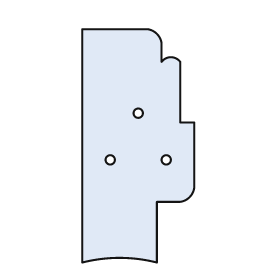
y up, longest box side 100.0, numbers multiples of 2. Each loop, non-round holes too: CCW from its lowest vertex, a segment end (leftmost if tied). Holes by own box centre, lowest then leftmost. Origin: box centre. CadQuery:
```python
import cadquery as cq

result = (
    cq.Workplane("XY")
    .moveTo(-24.0, -50.0)
    .threePointArc((-8.0, -48.0), (8.0, -50.0))
    .lineTo(8.0, -24.0)
    .lineTo(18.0, -24.0)
    .threePointArc((22.0, -22.0), (24.0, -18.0))
    .lineTo(24.0, 10.0)
    .lineTo(18.0, 10.0)
    .lineTo(18.0, 36.0)
    .threePointArc((14.0, 38.0), (10.0, 36.0))
    .lineTo(10.0, 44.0)
    .threePointArc((8.0, 48.0), (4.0, 50.0))
    .lineTo(-24.0, 50.0)
    .close()
    .moveTo(-12.0, -6.0)
    .circle(2.0)
    .moveTo(12.0, -6.0)
    .circle(2.0)
    .moveTo(0.0, 14.0)
    .circle(2.0)
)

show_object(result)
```